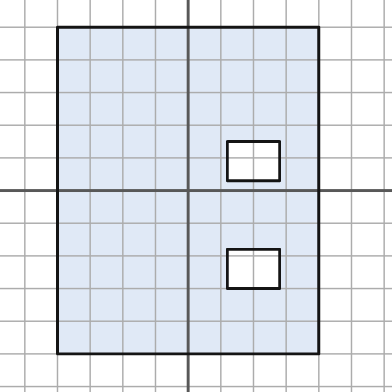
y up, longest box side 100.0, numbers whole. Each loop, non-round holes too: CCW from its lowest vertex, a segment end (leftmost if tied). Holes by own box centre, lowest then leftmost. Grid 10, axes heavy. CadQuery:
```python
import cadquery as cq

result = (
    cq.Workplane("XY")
    .moveTo(-40.0, -50.0)
    .lineTo(40.0, -50.0)
    .lineTo(40.0, 50.0)
    .lineTo(-40.0, 50.0)
    .close()
    .moveTo(12.0, -30.0)
    .lineTo(28.0, -30.0)
    .lineTo(28.0, -18.0)
    .lineTo(12.0, -18.0)
    .close()
    .moveTo(12.0, 3.0)
    .lineTo(28.0, 3.0)
    .lineTo(28.0, 15.0)
    .lineTo(12.0, 15.0)
    .close()
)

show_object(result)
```